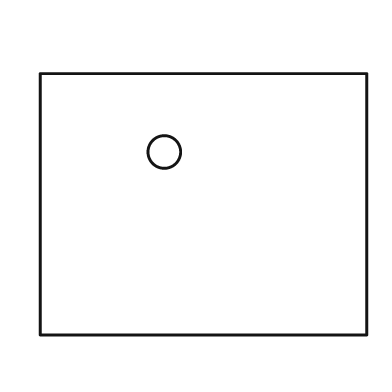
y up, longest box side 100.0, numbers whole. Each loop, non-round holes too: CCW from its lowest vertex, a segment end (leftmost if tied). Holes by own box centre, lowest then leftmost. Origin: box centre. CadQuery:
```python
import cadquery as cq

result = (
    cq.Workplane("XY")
    .moveTo(-50.0, -40.0)
    .lineTo(50.0, -40.0)
    .lineTo(50.0, 40.0)
    .lineTo(-50.0, 40.0)
    .close()
    .moveTo(-12.0, 16.0)
    .circle(5.0)
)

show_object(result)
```